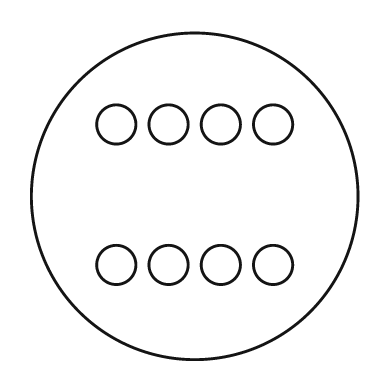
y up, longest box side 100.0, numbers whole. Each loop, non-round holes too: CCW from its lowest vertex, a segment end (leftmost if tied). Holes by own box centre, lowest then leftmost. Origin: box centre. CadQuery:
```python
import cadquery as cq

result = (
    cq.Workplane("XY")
    .moveTo(0.0, 0.0)
    .circle(50.0)
    .moveTo(-24.0, -21.0)
    .circle(6.0)
    .moveTo(-8.0, -21.0)
    .circle(6.0)
    .moveTo(8.0, -21.0)
    .circle(6.0)
    .moveTo(24.0, -21.0)
    .circle(6.0)
    .moveTo(-24.0, 22.0)
    .circle(6.0)
    .moveTo(-8.0, 22.0)
    .circle(6.0)
    .moveTo(8.0, 22.0)
    .circle(6.0)
    .moveTo(24.0, 22.0)
    .circle(6.0)
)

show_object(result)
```